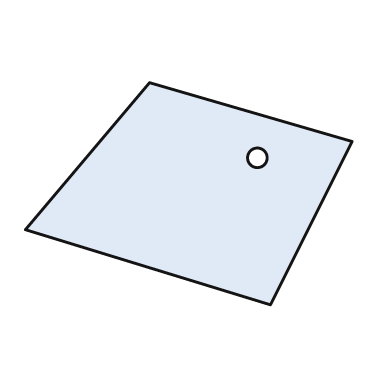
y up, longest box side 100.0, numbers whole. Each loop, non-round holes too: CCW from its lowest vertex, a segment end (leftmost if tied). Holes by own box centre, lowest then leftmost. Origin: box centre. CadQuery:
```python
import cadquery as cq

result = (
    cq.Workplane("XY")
    .moveTo(25.0, -34.0)
    .lineTo(50.0, 16.0)
    .lineTo(-12.0, 34.0)
    .lineTo(-50.0, -11.0)
    .close()
    .moveTo(21.0, 11.0)
    .circle(3.0)
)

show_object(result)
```